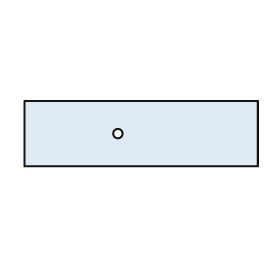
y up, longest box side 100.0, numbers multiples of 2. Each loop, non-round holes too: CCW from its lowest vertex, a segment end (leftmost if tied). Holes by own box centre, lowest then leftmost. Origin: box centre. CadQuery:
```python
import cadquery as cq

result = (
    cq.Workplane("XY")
    .moveTo(-50.0, -14.0)
    .lineTo(50.0, -14.0)
    .lineTo(50.0, 14.0)
    .lineTo(-50.0, 14.0)
    .close()
    .moveTo(-10.0, 0.0)
    .circle(2.0)
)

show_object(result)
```